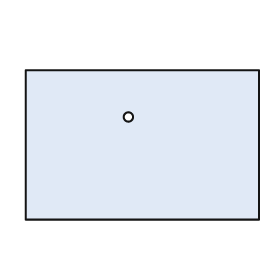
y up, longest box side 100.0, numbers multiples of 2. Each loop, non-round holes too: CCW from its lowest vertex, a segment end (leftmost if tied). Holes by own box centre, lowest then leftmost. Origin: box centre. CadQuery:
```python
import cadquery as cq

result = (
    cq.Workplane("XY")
    .moveTo(-50.0, -32.0)
    .lineTo(50.0, -32.0)
    .lineTo(50.0, 32.0)
    .lineTo(-50.0, 32.0)
    .close()
    .moveTo(-6.0, 12.0)
    .circle(2.0)
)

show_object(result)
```